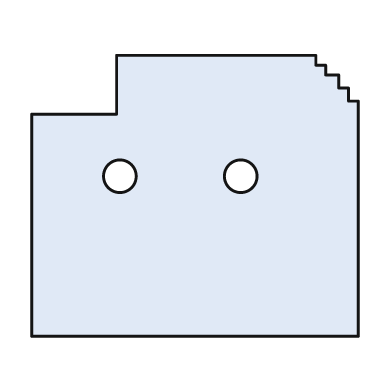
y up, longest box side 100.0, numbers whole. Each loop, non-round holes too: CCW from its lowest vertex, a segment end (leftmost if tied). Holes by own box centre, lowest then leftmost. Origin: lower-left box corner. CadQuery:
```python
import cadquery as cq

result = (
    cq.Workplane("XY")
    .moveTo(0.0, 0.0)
    .lineTo(100.0, 0.0)
    .lineTo(100.0, 72.0)
    .lineTo(97.0, 72.0)
    .lineTo(97.0, 76.0)
    .lineTo(94.0, 76.0)
    .lineTo(94.0, 80.0)
    .lineTo(90.0, 80.0)
    .lineTo(90.0, 83.0)
    .lineTo(87.0, 83.0)
    .lineTo(87.0, 86.0)
    .lineTo(26.0, 86.0)
    .lineTo(26.0, 68.0)
    .lineTo(0.0, 68.0)
    .close()
    .moveTo(27.0, 49.0)
    .circle(5.0)
    .moveTo(64.0, 49.0)
    .circle(5.0)
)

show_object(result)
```